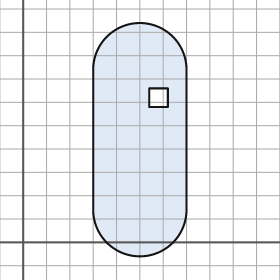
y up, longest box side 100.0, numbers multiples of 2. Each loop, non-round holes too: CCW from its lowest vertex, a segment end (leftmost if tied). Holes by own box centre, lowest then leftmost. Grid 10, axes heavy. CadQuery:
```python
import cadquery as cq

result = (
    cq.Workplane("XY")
    .moveTo(30.0, 14.0)
    .threePointArc((50.0, -6.0), (70.0, 14.0))
    .lineTo(70.0, 74.0)
    .threePointArc((50.0, 94.0), (30.0, 74.0))
    .close()
    .moveTo(54.0, 58.0)
    .lineTo(62.0, 58.0)
    .lineTo(62.0, 66.0)
    .lineTo(54.0, 66.0)
    .close()
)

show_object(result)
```